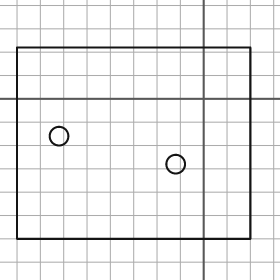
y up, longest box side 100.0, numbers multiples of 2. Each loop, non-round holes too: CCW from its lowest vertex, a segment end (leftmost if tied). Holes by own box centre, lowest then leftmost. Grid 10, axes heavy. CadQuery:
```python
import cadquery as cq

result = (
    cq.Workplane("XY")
    .moveTo(-80.0, -60.0)
    .lineTo(20.0, -60.0)
    .lineTo(20.0, 22.0)
    .lineTo(-80.0, 22.0)
    .close()
    .moveTo(-12.0, -28.0)
    .circle(4.0)
    .moveTo(-62.0, -16.0)
    .circle(4.0)
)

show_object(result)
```